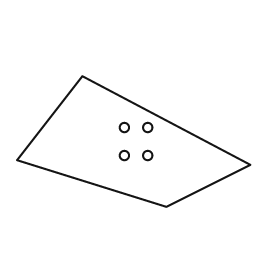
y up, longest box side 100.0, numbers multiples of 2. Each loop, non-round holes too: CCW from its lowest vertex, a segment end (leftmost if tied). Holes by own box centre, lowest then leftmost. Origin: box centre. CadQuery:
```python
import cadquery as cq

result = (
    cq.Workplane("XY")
    .moveTo(14.0, -28.0)
    .lineTo(50.0, -10.0)
    .lineTo(-22.0, 28.0)
    .lineTo(-50.0, -8.0)
    .close()
    .moveTo(-4.0, -6.0)
    .circle(2.0)
    .moveTo(6.0, -6.0)
    .circle(2.0)
    .moveTo(-4.0, 6.0)
    .circle(2.0)
    .moveTo(6.0, 6.0)
    .circle(2.0)
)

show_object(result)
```